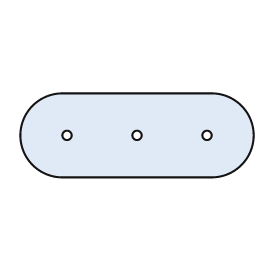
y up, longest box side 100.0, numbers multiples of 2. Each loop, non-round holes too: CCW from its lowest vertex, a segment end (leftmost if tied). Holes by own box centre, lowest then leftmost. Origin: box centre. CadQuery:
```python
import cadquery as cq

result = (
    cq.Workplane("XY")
    .moveTo(-32.0, -18.0)
    .lineTo(32.0, -18.0)
    .threePointArc((50.0, 0.0), (32.0, 18.0))
    .lineTo(-32.0, 18.0)
    .threePointArc((-50.0, 0.0), (-32.0, -18.0))
    .close()
    .moveTo(-30.0, 0.0)
    .circle(2.0)
    .moveTo(0.0, 0.0)
    .circle(2.0)
    .moveTo(30.0, 0.0)
    .circle(2.0)
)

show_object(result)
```